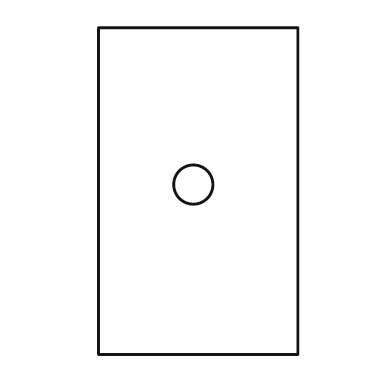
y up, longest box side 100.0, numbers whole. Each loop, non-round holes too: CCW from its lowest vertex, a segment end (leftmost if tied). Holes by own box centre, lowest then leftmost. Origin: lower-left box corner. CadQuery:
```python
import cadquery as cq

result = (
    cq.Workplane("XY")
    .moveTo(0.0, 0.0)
    .lineTo(61.0, 0.0)
    .lineTo(61.0, 100.0)
    .lineTo(0.0, 100.0)
    .close()
    .moveTo(29.0, 52.0)
    .circle(6.0)
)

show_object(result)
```